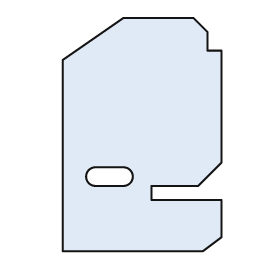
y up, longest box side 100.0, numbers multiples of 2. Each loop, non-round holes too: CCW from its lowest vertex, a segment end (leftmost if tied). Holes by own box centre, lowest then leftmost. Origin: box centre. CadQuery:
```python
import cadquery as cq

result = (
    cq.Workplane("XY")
    .moveTo(-34.0, -50.0)
    .lineTo(26.0, -50.0)
    .lineTo(34.0, -44.0)
    .lineTo(34.0, -28.0)
    .lineTo(4.0, -28.0)
    .lineTo(4.0, -22.0)
    .lineTo(24.0, -22.0)
    .lineTo(34.0, -12.0)
    .lineTo(34.0, 36.0)
    .lineTo(28.0, 36.0)
    .lineTo(28.0, 44.0)
    .lineTo(22.0, 50.0)
    .lineTo(-8.0, 50.0)
    .lineTo(-34.0, 32.0)
    .close()
    .moveTo(-20.0, -22.0)
    .lineTo(-8.0, -22.0)
    .threePointArc((-4.0, -18.0), (-8.0, -14.0))
    .lineTo(-20.0, -14.0)
    .threePointArc((-24.0, -18.0), (-20.0, -22.0))
    .close()
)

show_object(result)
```